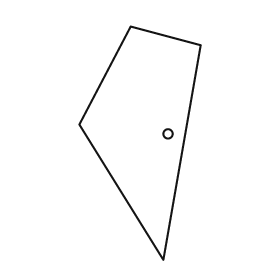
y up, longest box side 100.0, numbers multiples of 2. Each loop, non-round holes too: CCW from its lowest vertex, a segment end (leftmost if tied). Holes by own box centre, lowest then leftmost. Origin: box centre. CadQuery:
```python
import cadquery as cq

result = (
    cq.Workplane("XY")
    .moveTo(10.0, -50.0)
    .lineTo(26.0, 42.0)
    .lineTo(-4.0, 50.0)
    .lineTo(-26.0, 8.0)
    .close()
    .moveTo(12.0, 4.0)
    .circle(2.0)
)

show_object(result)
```